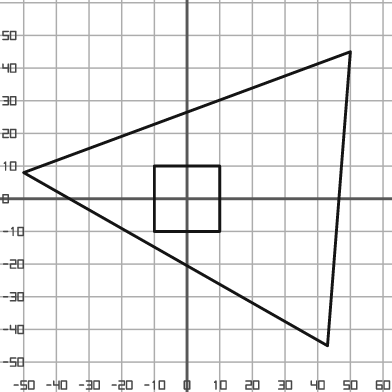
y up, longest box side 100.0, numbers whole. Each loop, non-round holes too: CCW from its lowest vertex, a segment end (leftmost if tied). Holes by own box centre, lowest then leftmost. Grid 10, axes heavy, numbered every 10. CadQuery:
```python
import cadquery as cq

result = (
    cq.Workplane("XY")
    .moveTo(43.0, -45.0)
    .lineTo(50.0, 45.0)
    .lineTo(-50.0, 8.0)
    .close()
    .moveTo(-10.0, -10.0)
    .lineTo(10.0, -10.0)
    .lineTo(10.0, 10.0)
    .lineTo(-10.0, 10.0)
    .close()
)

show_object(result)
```